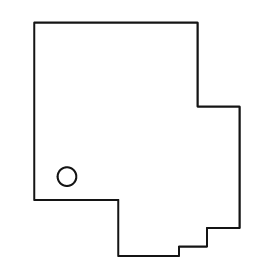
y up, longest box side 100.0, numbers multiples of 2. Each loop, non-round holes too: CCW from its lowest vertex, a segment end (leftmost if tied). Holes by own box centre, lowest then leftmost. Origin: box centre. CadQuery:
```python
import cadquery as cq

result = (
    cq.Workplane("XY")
    .moveTo(-8.0, -50.0)
    .lineTo(18.0, -50.0)
    .lineTo(18.0, -46.0)
    .lineTo(30.0, -46.0)
    .lineTo(30.0, -38.0)
    .lineTo(44.0, -38.0)
    .lineTo(44.0, 14.0)
    .lineTo(26.0, 14.0)
    .lineTo(26.0, 50.0)
    .lineTo(-44.0, 50.0)
    .lineTo(-44.0, -26.0)
    .lineTo(-8.0, -26.0)
    .close()
    .moveTo(-30.0, -16.0)
    .circle(4.0)
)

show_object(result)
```